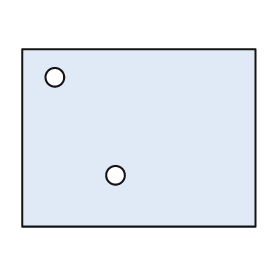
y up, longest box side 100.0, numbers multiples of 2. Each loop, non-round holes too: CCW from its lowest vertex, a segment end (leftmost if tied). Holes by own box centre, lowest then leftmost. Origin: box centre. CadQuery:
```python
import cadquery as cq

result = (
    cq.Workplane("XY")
    .moveTo(-50.0, -38.0)
    .lineTo(50.0, -38.0)
    .lineTo(50.0, 38.0)
    .lineTo(-50.0, 38.0)
    .close()
    .moveTo(-10.0, -16.0)
    .circle(4.0)
    .moveTo(-36.0, 26.0)
    .circle(4.0)
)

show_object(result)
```